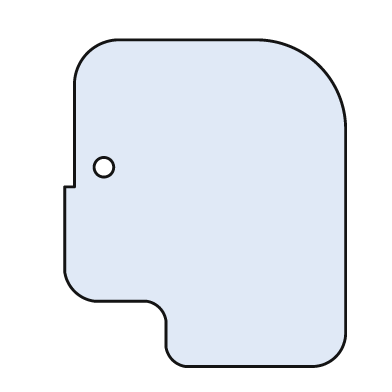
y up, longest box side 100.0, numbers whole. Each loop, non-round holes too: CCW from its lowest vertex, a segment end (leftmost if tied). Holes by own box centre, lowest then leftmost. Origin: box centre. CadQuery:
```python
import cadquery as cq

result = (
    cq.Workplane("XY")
    .moveTo(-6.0, -50.0)
    .lineTo(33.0, -50.0)
    .threePointArc((40.0, -47.0), (43.0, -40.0))
    .lineTo(43.0, 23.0)
    .threePointArc((35.0, 42.0), (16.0, 50.0))
    .lineTo(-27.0, 50.0)
    .threePointArc((-36.0, 46.0), (-40.0, 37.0))
    .lineTo(-40.0, 5.0)
    .lineTo(-43.0, 5.0)
    .lineTo(-43.0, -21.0)
    .threePointArc((-40.0, -27.0), (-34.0, -30.0))
    .lineTo(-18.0, -30.0)
    .threePointArc((-14.0, -32.0), (-12.0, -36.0))
    .lineTo(-12.0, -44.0)
    .threePointArc((-10.0, -48.0), (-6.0, -50.0))
    .close()
    .moveTo(-31.0, 11.0)
    .circle(3.0)
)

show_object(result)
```